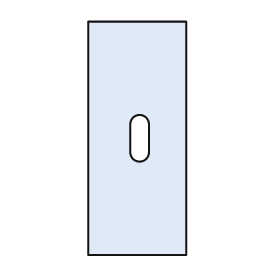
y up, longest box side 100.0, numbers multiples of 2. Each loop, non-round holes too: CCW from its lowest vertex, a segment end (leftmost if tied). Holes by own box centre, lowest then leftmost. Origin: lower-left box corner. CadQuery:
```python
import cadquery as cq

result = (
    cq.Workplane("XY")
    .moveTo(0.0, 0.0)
    .lineTo(42.0, 0.0)
    .lineTo(42.0, 100.0)
    .lineTo(0.0, 100.0)
    .close()
    .moveTo(18.0, 44.0)
    .threePointArc((22.0, 40.0), (26.0, 44.0))
    .lineTo(26.0, 56.0)
    .threePointArc((22.0, 60.0), (18.0, 56.0))
    .close()
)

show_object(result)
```